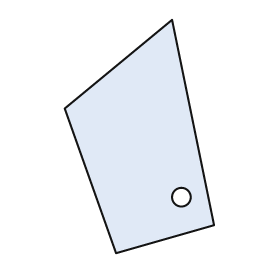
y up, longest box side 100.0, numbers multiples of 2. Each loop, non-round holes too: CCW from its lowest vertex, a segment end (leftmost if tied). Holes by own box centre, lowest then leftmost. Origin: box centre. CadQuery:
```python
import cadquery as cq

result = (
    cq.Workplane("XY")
    .moveTo(-10.0, -50.0)
    .lineTo(32.0, -38.0)
    .lineTo(14.0, 50.0)
    .lineTo(-32.0, 12.0)
    .close()
    .moveTo(18.0, -26.0)
    .circle(4.0)
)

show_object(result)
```